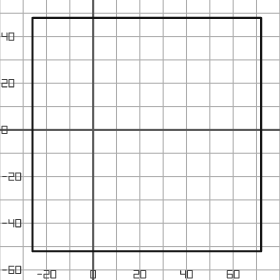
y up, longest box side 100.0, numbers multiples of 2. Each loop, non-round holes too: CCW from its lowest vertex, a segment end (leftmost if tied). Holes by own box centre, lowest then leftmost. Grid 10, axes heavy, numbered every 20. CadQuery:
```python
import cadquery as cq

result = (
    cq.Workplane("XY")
    .moveTo(-26.0, -52.0)
    .lineTo(72.0, -52.0)
    .lineTo(72.0, 48.0)
    .lineTo(-26.0, 48.0)
    .close()
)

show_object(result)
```